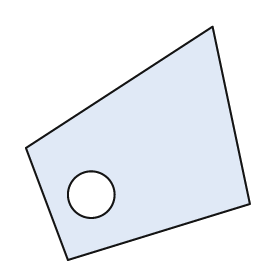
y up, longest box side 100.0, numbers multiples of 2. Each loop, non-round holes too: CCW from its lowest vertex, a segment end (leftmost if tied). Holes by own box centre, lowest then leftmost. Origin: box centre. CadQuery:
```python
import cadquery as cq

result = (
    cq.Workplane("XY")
    .moveTo(-30.0, -50.0)
    .lineTo(48.0, -26.0)
    .lineTo(32.0, 50.0)
    .lineTo(-48.0, -2.0)
    .close()
    .moveTo(-20.0, -22.0)
    .circle(10.0)
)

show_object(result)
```